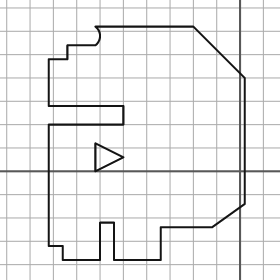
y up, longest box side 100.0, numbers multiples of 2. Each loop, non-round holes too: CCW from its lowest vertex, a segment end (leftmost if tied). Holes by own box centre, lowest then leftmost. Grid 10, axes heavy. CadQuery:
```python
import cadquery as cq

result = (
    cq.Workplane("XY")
    .moveTo(-76.0, -38.0)
    .lineTo(-60.0, -38.0)
    .lineTo(-60.0, -22.0)
    .lineTo(-54.0, -22.0)
    .lineTo(-54.0, -38.0)
    .lineTo(-34.0, -38.0)
    .lineTo(-34.0, -24.0)
    .lineTo(-12.0, -24.0)
    .lineTo(2.0, -14.0)
    .lineTo(2.0, 40.0)
    .lineTo(-20.0, 62.0)
    .lineTo(-62.0, 62.0)
    .threePointArc((-60.0, 58.0), (-62.0, 54.0))
    .lineTo(-74.0, 54.0)
    .lineTo(-74.0, 48.0)
    .lineTo(-82.0, 48.0)
    .lineTo(-82.0, 28.0)
    .lineTo(-50.0, 28.0)
    .lineTo(-50.0, 20.0)
    .lineTo(-82.0, 20.0)
    .lineTo(-82.0, -32.0)
    .lineTo(-76.0, -32.0)
    .close()
    .moveTo(-62.0, 0.0)
    .lineTo(-50.0, 6.0)
    .lineTo(-62.0, 12.0)
    .close()
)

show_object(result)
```